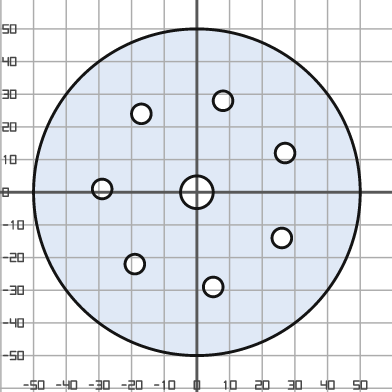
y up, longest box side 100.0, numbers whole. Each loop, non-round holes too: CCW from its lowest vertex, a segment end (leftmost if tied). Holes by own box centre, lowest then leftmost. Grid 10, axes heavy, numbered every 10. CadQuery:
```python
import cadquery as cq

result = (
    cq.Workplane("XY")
    .moveTo(0.0, 0.0)
    .circle(50.0)
    .moveTo(5.0, -29.0)
    .circle(3.0)
    .moveTo(-19.0, -22.0)
    .circle(3.0)
    .moveTo(26.0, -14.0)
    .circle(3.0)
    .moveTo(0.0, 0.0)
    .circle(5.0)
    .moveTo(-29.0, 1.0)
    .circle(3.0)
    .moveTo(27.0, 12.0)
    .circle(3.0)
    .moveTo(-17.0, 24.0)
    .circle(3.0)
    .moveTo(8.0, 28.0)
    .circle(3.0)
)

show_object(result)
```